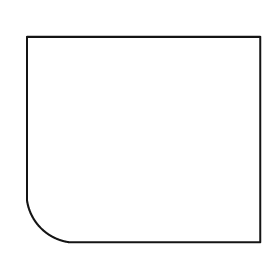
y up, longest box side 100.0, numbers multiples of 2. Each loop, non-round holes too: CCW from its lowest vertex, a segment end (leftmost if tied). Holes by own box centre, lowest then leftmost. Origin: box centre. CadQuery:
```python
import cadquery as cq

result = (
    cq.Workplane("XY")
    .moveTo(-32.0, -44.0)
    .lineTo(50.0, -44.0)
    .lineTo(50.0, 44.0)
    .lineTo(-50.0, 44.0)
    .lineTo(-50.0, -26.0)
    .threePointArc((-44.0, -38.0), (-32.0, -44.0))
    .close()
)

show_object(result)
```